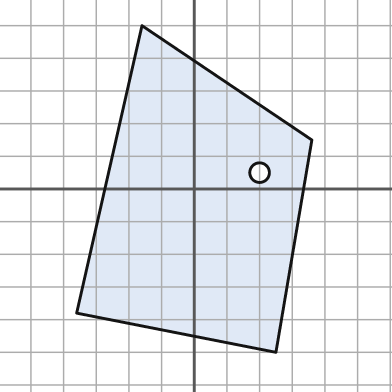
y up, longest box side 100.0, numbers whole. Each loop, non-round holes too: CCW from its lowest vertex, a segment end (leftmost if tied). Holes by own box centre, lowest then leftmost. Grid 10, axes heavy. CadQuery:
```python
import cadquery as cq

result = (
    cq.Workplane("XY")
    .moveTo(25.0, -50.0)
    .lineTo(36.0, 15.0)
    .lineTo(-16.0, 50.0)
    .lineTo(-36.0, -38.0)
    .close()
    .moveTo(20.0, 5.0)
    .circle(3.0)
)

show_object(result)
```